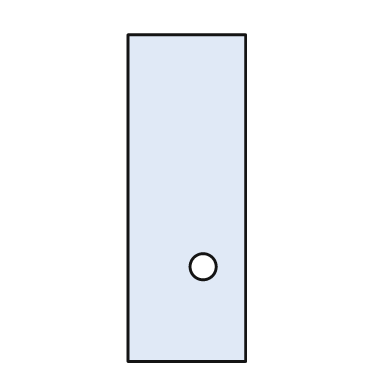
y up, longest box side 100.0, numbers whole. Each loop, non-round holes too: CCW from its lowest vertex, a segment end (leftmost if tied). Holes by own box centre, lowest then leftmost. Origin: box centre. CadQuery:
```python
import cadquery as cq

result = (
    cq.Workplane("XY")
    .moveTo(-18.0, -50.0)
    .lineTo(18.0, -50.0)
    .lineTo(18.0, 50.0)
    .lineTo(-18.0, 50.0)
    .close()
    .moveTo(5.0, -21.0)
    .circle(4.0)
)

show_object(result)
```